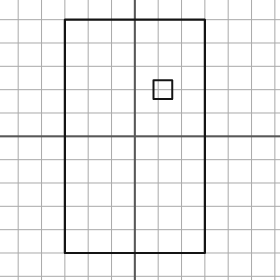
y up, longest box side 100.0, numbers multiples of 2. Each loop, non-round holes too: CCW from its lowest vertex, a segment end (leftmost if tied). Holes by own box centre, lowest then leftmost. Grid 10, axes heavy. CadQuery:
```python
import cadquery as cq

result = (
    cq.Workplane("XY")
    .moveTo(-30.0, -50.0)
    .lineTo(30.0, -50.0)
    .lineTo(30.0, 50.0)
    .lineTo(-30.0, 50.0)
    .close()
    .moveTo(8.0, 16.0)
    .lineTo(16.0, 16.0)
    .lineTo(16.0, 24.0)
    .lineTo(8.0, 24.0)
    .close()
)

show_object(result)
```